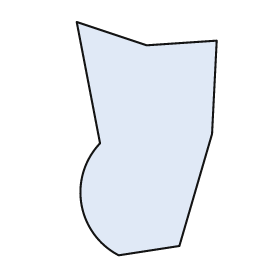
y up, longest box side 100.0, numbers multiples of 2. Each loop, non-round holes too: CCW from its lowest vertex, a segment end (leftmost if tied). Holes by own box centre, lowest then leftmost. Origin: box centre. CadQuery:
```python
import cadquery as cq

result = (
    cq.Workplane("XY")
    .moveTo(-12.0, -50.0)
    .lineTo(14.0, -46.0)
    .lineTo(28.0, 2.0)
    .lineTo(30.0, 42.0)
    .lineTo(0.0, 40.0)
    .lineTo(-30.0, 50.0)
    .lineTo(-20.0, -2.0)
    .threePointArc((-28.0, -28.0), (-12.0, -50.0))
    .close()
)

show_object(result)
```